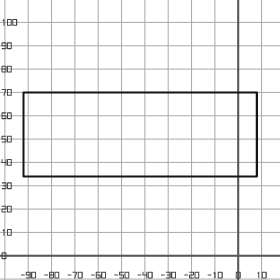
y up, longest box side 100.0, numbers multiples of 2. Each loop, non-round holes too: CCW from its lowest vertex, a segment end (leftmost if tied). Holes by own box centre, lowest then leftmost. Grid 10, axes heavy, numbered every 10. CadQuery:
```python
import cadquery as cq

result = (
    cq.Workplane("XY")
    .moveTo(-92.0, 34.0)
    .lineTo(8.0, 34.0)
    .lineTo(8.0, 70.0)
    .lineTo(-92.0, 70.0)
    .close()
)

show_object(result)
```